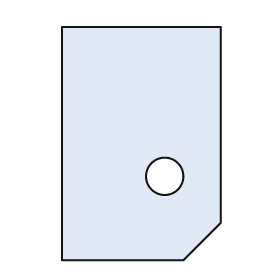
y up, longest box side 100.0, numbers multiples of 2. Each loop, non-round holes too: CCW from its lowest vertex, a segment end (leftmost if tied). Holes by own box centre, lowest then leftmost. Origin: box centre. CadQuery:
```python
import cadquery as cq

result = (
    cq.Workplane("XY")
    .moveTo(-34.0, -50.0)
    .lineTo(18.0, -50.0)
    .lineTo(34.0, -34.0)
    .lineTo(34.0, 50.0)
    .lineTo(-34.0, 50.0)
    .close()
    .moveTo(10.0, -14.0)
    .circle(8.0)
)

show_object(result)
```